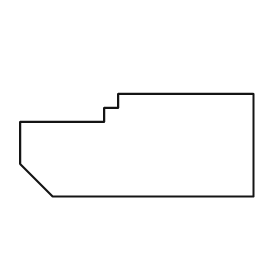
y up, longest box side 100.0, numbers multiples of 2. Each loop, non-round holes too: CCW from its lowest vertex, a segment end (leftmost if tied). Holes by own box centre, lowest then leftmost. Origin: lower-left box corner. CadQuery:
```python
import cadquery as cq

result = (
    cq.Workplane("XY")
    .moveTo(14.0, 0.0)
    .lineTo(100.0, 0.0)
    .lineTo(100.0, 44.0)
    .lineTo(42.0, 44.0)
    .lineTo(42.0, 38.0)
    .lineTo(36.0, 38.0)
    .lineTo(36.0, 32.0)
    .lineTo(0.0, 32.0)
    .lineTo(0.0, 14.0)
    .close()
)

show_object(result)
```